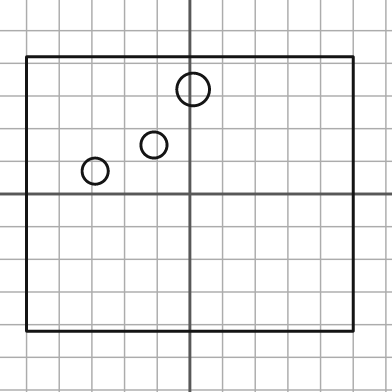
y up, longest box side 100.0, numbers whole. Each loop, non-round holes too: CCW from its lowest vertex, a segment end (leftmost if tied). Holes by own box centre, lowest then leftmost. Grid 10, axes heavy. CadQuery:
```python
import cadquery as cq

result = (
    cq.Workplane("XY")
    .moveTo(-50.0, -42.0)
    .lineTo(50.0, -42.0)
    .lineTo(50.0, 42.0)
    .lineTo(-50.0, 42.0)
    .close()
    .moveTo(-29.0, 7.0)
    .circle(4.0)
    .moveTo(-11.0, 15.0)
    .circle(4.0)
    .moveTo(1.0, 32.0)
    .circle(5.0)
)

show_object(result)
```